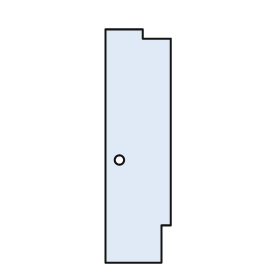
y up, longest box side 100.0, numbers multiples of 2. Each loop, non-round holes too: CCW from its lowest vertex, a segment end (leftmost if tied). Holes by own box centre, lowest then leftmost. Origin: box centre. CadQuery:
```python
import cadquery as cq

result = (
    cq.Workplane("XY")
    .moveTo(-14.0, -50.0)
    .lineTo(10.0, -50.0)
    .lineTo(10.0, -34.0)
    .lineTo(14.0, -34.0)
    .lineTo(14.0, 46.0)
    .lineTo(2.0, 46.0)
    .lineTo(2.0, 50.0)
    .lineTo(-14.0, 50.0)
    .close()
    .moveTo(-8.0, -6.0)
    .circle(2.0)
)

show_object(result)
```